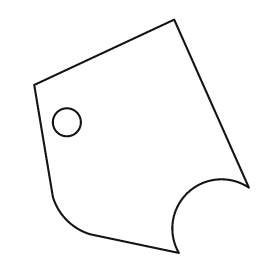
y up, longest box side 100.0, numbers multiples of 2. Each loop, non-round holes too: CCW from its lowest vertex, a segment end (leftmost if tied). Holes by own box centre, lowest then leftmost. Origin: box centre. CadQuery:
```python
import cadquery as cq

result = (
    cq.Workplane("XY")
    .moveTo(16.0, -50.0)
    .threePointArc((20.0, -24.0), (46.0, -22.0))
    .lineTo(14.0, 50.0)
    .lineTo(-46.0, 22.0)
    .lineTo(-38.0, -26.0)
    .threePointArc((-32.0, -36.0), (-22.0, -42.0))
    .close()
    .moveTo(-32.0, 6.0)
    .circle(6.0)
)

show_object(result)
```